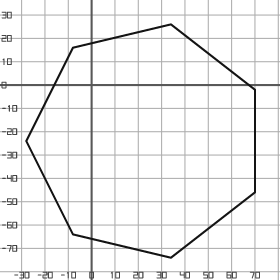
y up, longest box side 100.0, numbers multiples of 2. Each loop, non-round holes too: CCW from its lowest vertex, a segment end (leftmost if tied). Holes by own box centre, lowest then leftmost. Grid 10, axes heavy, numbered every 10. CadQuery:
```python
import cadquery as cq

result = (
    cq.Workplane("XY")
    .moveTo(34.0, -74.0)
    .lineTo(70.0, -46.0)
    .lineTo(70.0, -2.0)
    .lineTo(34.0, 26.0)
    .lineTo(-8.0, 16.0)
    .lineTo(-28.0, -24.0)
    .lineTo(-8.0, -64.0)
    .close()
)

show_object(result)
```